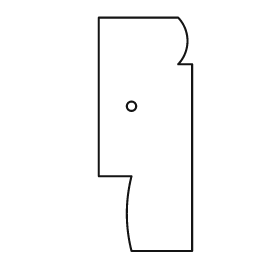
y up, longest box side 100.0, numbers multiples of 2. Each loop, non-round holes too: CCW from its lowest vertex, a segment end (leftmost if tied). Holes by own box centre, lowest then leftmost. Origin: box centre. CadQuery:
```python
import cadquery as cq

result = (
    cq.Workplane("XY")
    .moveTo(-6.0, -50.0)
    .lineTo(20.0, -50.0)
    .lineTo(20.0, 30.0)
    .lineTo(14.0, 30.0)
    .threePointArc((18.0, 40.0), (14.0, 50.0))
    .lineTo(-20.0, 50.0)
    .lineTo(-20.0, -18.0)
    .lineTo(-6.0, -18.0)
    .threePointArc((-8.0, -34.0), (-6.0, -50.0))
    .close()
    .moveTo(-6.0, 12.0)
    .circle(2.0)
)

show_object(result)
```